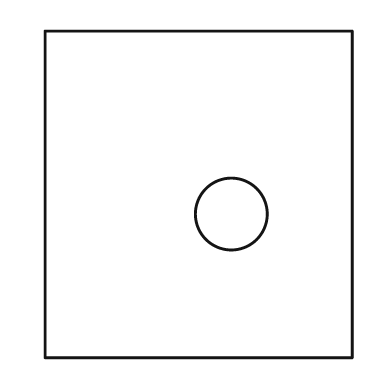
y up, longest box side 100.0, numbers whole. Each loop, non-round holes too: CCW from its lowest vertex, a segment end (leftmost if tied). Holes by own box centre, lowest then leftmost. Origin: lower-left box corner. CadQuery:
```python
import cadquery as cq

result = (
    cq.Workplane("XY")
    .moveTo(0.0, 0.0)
    .lineTo(94.0, 0.0)
    .lineTo(94.0, 100.0)
    .lineTo(0.0, 100.0)
    .close()
    .moveTo(57.0, 44.0)
    .circle(11.0)
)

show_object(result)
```